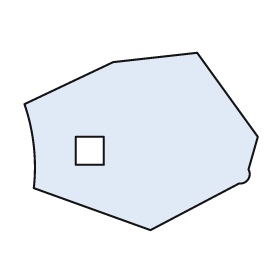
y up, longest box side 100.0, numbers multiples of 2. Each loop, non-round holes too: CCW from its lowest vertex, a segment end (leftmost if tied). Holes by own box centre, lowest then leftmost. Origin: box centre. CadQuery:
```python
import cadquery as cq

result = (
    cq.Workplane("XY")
    .moveTo(4.0, -38.0)
    .lineTo(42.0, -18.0)
    .threePointArc((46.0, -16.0), (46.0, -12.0))
    .lineTo(50.0, 2.0)
    .lineTo(24.0, 38.0)
    .lineTo(-12.0, 34.0)
    .lineTo(-50.0, 16.0)
    .threePointArc((-46.0, -2.0), (-46.0, -20.0))
    .close()
    .moveTo(-28.0, -10.0)
    .lineTo(-16.0, -10.0)
    .lineTo(-16.0, 2.0)
    .lineTo(-28.0, 2.0)
    .close()
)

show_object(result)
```